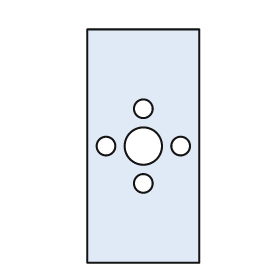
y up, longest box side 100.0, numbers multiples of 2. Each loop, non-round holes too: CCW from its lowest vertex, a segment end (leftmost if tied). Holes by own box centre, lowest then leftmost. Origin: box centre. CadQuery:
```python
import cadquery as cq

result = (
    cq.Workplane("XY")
    .moveTo(-24.0, -50.0)
    .lineTo(24.0, -50.0)
    .lineTo(24.0, 50.0)
    .lineTo(-24.0, 50.0)
    .close()
    .moveTo(0.0, -16.0)
    .circle(4.0)
    .moveTo(-16.0, 0.0)
    .circle(4.0)
    .moveTo(0.0, 0.0)
    .circle(8.0)
    .moveTo(16.0, 0.0)
    .circle(4.0)
    .moveTo(0.0, 16.0)
    .circle(4.0)
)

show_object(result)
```